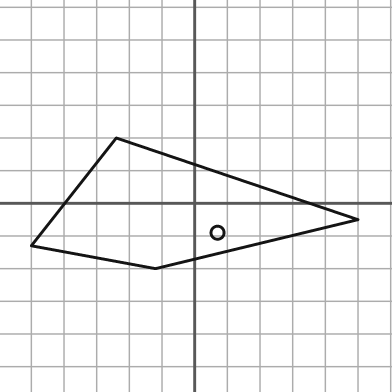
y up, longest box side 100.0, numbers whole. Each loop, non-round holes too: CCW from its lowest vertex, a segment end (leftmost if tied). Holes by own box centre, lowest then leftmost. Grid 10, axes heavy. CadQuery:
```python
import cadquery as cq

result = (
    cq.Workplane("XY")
    .moveTo(-12.0, -20.0)
    .lineTo(50.0, -5.0)
    .lineTo(-24.0, 20.0)
    .lineTo(-50.0, -13.0)
    .close()
    .moveTo(7.0, -9.0)
    .circle(2.0)
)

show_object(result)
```